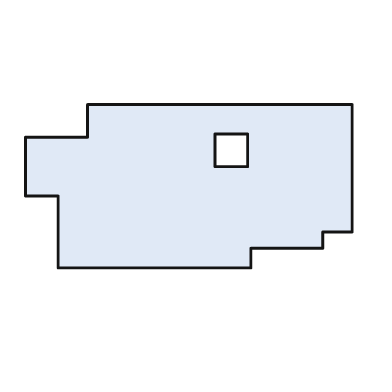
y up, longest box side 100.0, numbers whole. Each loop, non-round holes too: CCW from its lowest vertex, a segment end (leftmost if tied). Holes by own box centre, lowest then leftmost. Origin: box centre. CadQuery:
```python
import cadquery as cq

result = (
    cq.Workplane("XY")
    .moveTo(-40.0, -25.0)
    .lineTo(19.0, -25.0)
    .lineTo(19.0, -19.0)
    .lineTo(41.0, -19.0)
    .lineTo(41.0, -14.0)
    .lineTo(50.0, -14.0)
    .lineTo(50.0, 25.0)
    .lineTo(-31.0, 25.0)
    .lineTo(-31.0, 15.0)
    .lineTo(-50.0, 15.0)
    .lineTo(-50.0, -3.0)
    .lineTo(-40.0, -3.0)
    .close()
    .moveTo(8.0, 6.0)
    .lineTo(18.0, 6.0)
    .lineTo(18.0, 16.0)
    .lineTo(8.0, 16.0)
    .close()
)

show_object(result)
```